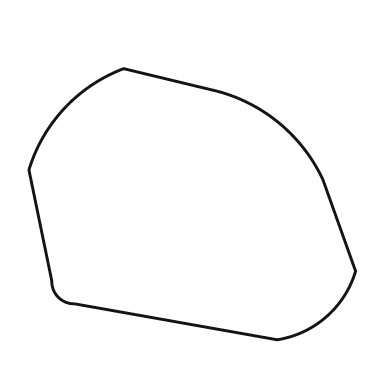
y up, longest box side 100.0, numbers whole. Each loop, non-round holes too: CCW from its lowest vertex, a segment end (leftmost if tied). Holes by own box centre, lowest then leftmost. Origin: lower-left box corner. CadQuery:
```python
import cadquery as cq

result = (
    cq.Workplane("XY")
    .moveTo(76.0, 0.0)
    .threePointArc((91.0, 7.0), (100.0, 21.0))
    .lineTo(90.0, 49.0)
    .threePointArc((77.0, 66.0), (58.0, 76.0))
    .lineTo(29.0, 83.0)
    .threePointArc((11.0, 71.0), (0.0, 52.0))
    .lineTo(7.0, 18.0)
    .threePointArc((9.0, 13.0), (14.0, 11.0))
    .close()
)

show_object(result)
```